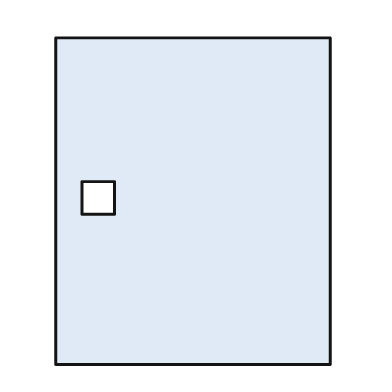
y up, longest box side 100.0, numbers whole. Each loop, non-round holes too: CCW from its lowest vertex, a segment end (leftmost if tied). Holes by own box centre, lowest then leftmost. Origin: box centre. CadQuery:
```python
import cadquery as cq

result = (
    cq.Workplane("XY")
    .moveTo(-42.0, -50.0)
    .lineTo(42.0, -50.0)
    .lineTo(42.0, 50.0)
    .lineTo(-42.0, 50.0)
    .close()
    .moveTo(-34.0, -4.0)
    .lineTo(-24.0, -4.0)
    .lineTo(-24.0, 6.0)
    .lineTo(-34.0, 6.0)
    .close()
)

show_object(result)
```